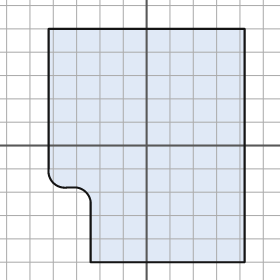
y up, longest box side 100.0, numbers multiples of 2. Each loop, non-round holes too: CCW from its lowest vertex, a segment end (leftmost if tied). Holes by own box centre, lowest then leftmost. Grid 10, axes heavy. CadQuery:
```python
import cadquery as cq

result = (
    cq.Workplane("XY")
    .moveTo(-24.0, -50.0)
    .lineTo(42.0, -50.0)
    .lineTo(42.0, 50.0)
    .lineTo(-42.0, 50.0)
    .lineTo(-42.0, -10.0)
    .threePointArc((-40.0, -16.0), (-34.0, -18.0))
    .lineTo(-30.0, -18.0)
    .threePointArc((-26.0, -20.0), (-24.0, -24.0))
    .close()
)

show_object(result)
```